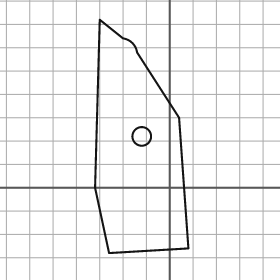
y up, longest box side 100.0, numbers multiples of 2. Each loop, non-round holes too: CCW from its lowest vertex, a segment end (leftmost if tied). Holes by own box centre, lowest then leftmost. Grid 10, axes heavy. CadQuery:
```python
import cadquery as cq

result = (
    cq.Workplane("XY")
    .moveTo(-26.0, -28.0)
    .lineTo(8.0, -26.0)
    .lineTo(4.0, 30.0)
    .lineTo(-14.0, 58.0)
    .threePointArc((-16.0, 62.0), (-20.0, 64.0))
    .lineTo(-30.0, 72.0)
    .lineTo(-32.0, 0.0)
    .close()
    .moveTo(-12.0, 22.0)
    .circle(4.0)
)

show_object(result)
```